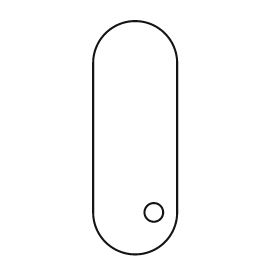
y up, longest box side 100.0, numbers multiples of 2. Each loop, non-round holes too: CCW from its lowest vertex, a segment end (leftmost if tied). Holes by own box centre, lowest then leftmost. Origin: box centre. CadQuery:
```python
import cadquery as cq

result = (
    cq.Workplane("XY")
    .moveTo(-18.0, -32.0)
    .threePointArc((0.0, -50.0), (18.0, -32.0))
    .lineTo(18.0, 32.0)
    .threePointArc((0.0, 50.0), (-18.0, 32.0))
    .close()
    .moveTo(8.0, -32.0)
    .circle(4.0)
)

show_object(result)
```